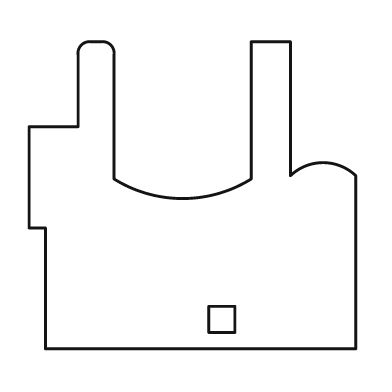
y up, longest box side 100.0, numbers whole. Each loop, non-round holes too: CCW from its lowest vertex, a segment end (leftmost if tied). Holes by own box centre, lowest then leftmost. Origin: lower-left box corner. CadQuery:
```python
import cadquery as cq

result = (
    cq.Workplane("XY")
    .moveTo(5.0, 0.0)
    .lineTo(100.0, 0.0)
    .lineTo(100.0, 53.0)
    .threePointArc((90.0, 57.0), (80.0, 53.0))
    .lineTo(80.0, 94.0)
    .lineTo(68.0, 94.0)
    .lineTo(68.0, 52.0)
    .threePointArc((47.0, 46.0), (26.0, 52.0))
    .lineTo(26.0, 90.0)
    .threePointArc((25.0, 93.0), (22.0, 94.0))
    .lineTo(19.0, 94.0)
    .threePointArc((16.0, 93.0), (15.0, 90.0))
    .lineTo(15.0, 68.0)
    .lineTo(0.0, 68.0)
    .lineTo(0.0, 37.0)
    .lineTo(5.0, 37.0)
    .close()
    .moveTo(55.0, 5.0)
    .lineTo(63.0, 5.0)
    .lineTo(63.0, 13.0)
    .lineTo(55.0, 13.0)
    .close()
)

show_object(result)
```